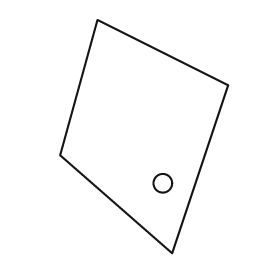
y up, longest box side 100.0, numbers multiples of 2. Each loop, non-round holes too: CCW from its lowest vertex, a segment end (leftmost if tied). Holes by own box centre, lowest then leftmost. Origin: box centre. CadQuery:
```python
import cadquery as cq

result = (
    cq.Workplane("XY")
    .moveTo(12.0, -50.0)
    .lineTo(36.0, 22.0)
    .lineTo(-20.0, 50.0)
    .lineTo(-36.0, -8.0)
    .close()
    .moveTo(8.0, -20.0)
    .circle(4.0)
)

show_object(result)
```